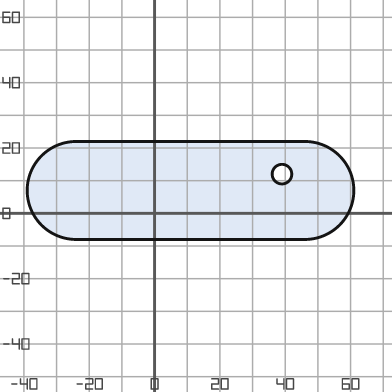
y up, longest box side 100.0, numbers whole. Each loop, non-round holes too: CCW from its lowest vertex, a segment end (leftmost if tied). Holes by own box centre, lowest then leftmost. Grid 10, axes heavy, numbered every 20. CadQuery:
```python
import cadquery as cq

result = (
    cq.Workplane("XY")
    .moveTo(-24.0, -8.0)
    .lineTo(46.0, -8.0)
    .threePointArc((61.0, 7.0), (46.0, 22.0))
    .lineTo(-24.0, 22.0)
    .threePointArc((-39.0, 7.0), (-24.0, -8.0))
    .close()
    .moveTo(39.0, 12.0)
    .circle(3.0)
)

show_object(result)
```